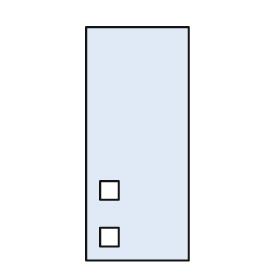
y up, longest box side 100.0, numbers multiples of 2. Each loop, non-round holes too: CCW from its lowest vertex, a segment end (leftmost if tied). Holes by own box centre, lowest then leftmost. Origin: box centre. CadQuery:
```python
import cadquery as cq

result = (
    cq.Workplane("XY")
    .moveTo(-22.0, -50.0)
    .lineTo(22.0, -50.0)
    .lineTo(22.0, 50.0)
    .lineTo(-22.0, 50.0)
    .close()
    .moveTo(-16.0, -44.0)
    .lineTo(-8.0, -44.0)
    .lineTo(-8.0, -36.0)
    .lineTo(-16.0, -36.0)
    .close()
    .moveTo(-16.0, -24.0)
    .lineTo(-8.0, -24.0)
    .lineTo(-8.0, -16.0)
    .lineTo(-16.0, -16.0)
    .close()
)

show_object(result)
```